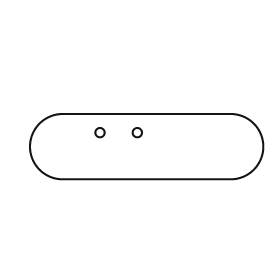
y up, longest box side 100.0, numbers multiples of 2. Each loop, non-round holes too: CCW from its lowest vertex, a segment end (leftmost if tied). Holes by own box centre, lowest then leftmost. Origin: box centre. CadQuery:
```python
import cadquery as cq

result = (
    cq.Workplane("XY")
    .moveTo(-36.0, -14.0)
    .lineTo(36.0, -14.0)
    .threePointArc((50.0, 0.0), (36.0, 14.0))
    .lineTo(-36.0, 14.0)
    .threePointArc((-50.0, 0.0), (-36.0, -14.0))
    .close()
    .moveTo(-20.0, 6.0)
    .circle(2.0)
    .moveTo(-4.0, 6.0)
    .circle(2.0)
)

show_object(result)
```